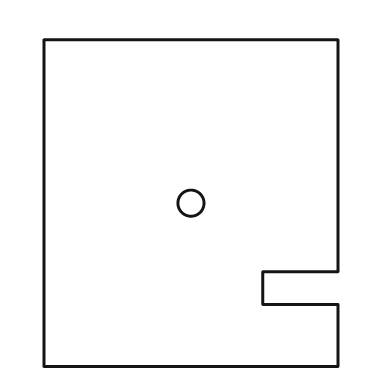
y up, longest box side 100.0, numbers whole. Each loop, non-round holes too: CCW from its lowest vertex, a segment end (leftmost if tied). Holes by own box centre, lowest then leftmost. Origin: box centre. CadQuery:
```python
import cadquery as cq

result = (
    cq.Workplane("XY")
    .moveTo(-45.0, -50.0)
    .lineTo(45.0, -50.0)
    .lineTo(45.0, -31.0)
    .lineTo(22.0, -31.0)
    .lineTo(22.0, -21.0)
    .lineTo(45.0, -21.0)
    .lineTo(45.0, 50.0)
    .lineTo(-45.0, 50.0)
    .close()
    .moveTo(0.0, 0.0)
    .circle(4.0)
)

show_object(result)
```